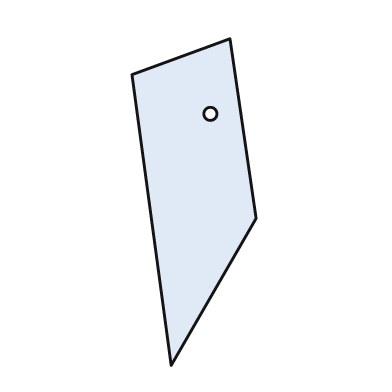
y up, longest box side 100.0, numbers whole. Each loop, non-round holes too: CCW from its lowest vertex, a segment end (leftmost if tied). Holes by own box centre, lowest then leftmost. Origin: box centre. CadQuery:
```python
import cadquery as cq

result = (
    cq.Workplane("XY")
    .moveTo(-7.0, -50.0)
    .lineTo(19.0, -5.0)
    .lineTo(11.0, 50.0)
    .lineTo(-19.0, 39.0)
    .close()
    .moveTo(5.0, 27.0)
    .circle(2.0)
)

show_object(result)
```